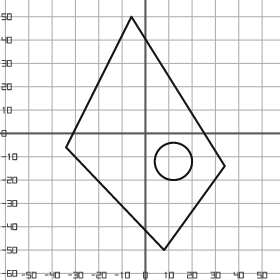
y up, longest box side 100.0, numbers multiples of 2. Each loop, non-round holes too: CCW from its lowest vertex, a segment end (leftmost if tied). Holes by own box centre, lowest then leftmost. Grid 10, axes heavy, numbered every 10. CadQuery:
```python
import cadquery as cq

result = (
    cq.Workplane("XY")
    .moveTo(8.0, -50.0)
    .lineTo(34.0, -14.0)
    .lineTo(-6.0, 50.0)
    .lineTo(-34.0, -6.0)
    .close()
    .moveTo(12.0, -12.0)
    .circle(8.0)
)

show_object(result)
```